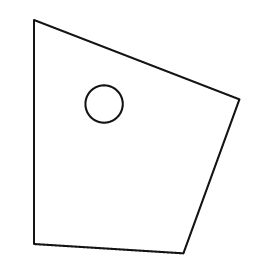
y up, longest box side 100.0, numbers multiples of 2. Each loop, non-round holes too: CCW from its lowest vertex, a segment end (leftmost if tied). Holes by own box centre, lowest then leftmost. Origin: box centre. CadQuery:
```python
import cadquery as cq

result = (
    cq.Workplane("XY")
    .moveTo(20.0, -50.0)
    .lineTo(44.0, 16.0)
    .lineTo(-44.0, 50.0)
    .lineTo(-44.0, -46.0)
    .close()
    .moveTo(-14.0, 14.0)
    .circle(8.0)
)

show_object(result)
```